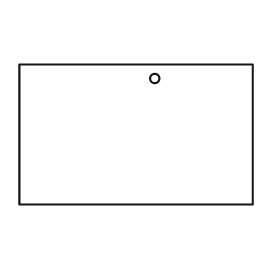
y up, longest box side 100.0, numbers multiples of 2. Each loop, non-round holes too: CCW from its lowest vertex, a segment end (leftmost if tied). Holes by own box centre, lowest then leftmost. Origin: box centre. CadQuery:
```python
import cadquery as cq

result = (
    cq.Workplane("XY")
    .moveTo(-50.0, -30.0)
    .lineTo(50.0, -30.0)
    .lineTo(50.0, 30.0)
    .lineTo(-50.0, 30.0)
    .close()
    .moveTo(8.0, 24.0)
    .circle(2.0)
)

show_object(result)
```